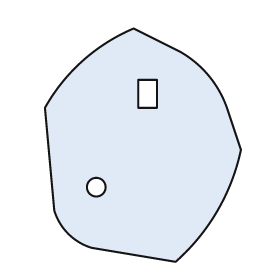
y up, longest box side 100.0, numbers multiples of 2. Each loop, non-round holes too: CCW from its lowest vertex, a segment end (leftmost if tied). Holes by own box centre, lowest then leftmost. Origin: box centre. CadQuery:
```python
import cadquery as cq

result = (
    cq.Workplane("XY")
    .moveTo(14.0, -50.0)
    .threePointArc((32.0, -28.0), (42.0, -2.0))
    .lineTo(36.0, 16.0)
    .threePointArc((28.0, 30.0), (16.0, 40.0))
    .lineTo(-4.0, 50.0)
    .threePointArc((-26.0, 36.0), (-42.0, 16.0))
    .lineTo(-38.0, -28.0)
    .threePointArc((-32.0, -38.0), (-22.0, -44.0))
    .close()
    .moveTo(-20.0, -18.0)
    .circle(4.0)
    .moveTo(-2.0, 16.0)
    .lineTo(6.0, 16.0)
    .lineTo(6.0, 28.0)
    .lineTo(-2.0, 28.0)
    .close()
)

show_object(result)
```